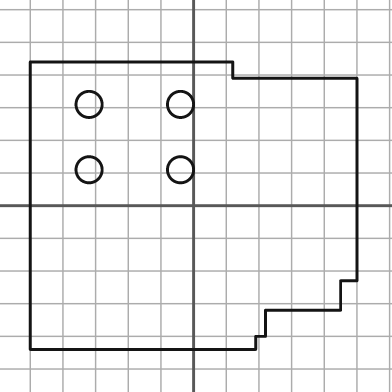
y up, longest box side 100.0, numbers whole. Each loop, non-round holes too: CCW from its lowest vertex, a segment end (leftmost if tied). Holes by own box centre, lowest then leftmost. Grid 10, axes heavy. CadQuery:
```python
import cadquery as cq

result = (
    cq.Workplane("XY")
    .moveTo(-50.0, -44.0)
    .lineTo(19.0, -44.0)
    .lineTo(19.0, -40.0)
    .lineTo(22.0, -40.0)
    .lineTo(22.0, -32.0)
    .lineTo(45.0, -32.0)
    .lineTo(45.0, -23.0)
    .lineTo(50.0, -23.0)
    .lineTo(50.0, 39.0)
    .lineTo(12.0, 39.0)
    .lineTo(12.0, 44.0)
    .lineTo(-50.0, 44.0)
    .close()
    .moveTo(-32.0, 11.0)
    .circle(4.0)
    .moveTo(-4.0, 11.0)
    .circle(4.0)
    .moveTo(-32.0, 31.0)
    .circle(4.0)
    .moveTo(-4.0, 31.0)
    .circle(4.0)
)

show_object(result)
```